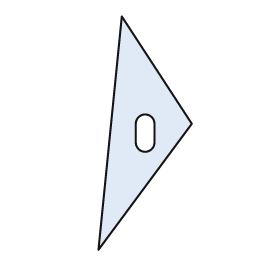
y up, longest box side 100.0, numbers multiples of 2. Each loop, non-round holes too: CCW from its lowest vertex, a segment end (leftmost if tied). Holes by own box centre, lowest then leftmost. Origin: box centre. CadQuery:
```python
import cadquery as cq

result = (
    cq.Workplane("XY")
    .moveTo(-20.0, -50.0)
    .lineTo(20.0, 4.0)
    .lineTo(-10.0, 50.0)
    .close()
    .moveTo(-4.0, -4.0)
    .threePointArc((0.0, -8.0), (4.0, -4.0))
    .lineTo(4.0, 4.0)
    .threePointArc((0.0, 8.0), (-4.0, 4.0))
    .close()
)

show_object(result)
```